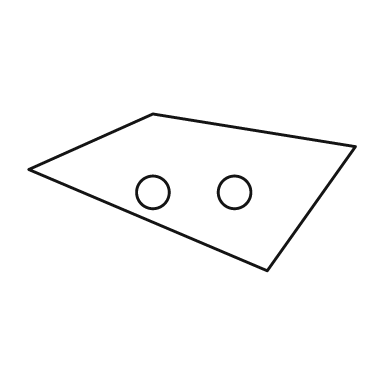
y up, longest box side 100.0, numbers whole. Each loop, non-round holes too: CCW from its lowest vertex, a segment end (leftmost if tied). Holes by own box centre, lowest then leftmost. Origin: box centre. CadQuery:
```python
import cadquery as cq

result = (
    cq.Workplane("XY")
    .moveTo(23.0, -24.0)
    .lineTo(50.0, 14.0)
    .lineTo(-12.0, 24.0)
    .lineTo(-50.0, 7.0)
    .close()
    .moveTo(-12.0, 0.0)
    .circle(5.0)
    .moveTo(13.0, 0.0)
    .circle(5.0)
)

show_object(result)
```